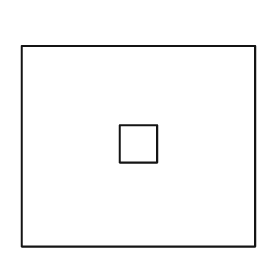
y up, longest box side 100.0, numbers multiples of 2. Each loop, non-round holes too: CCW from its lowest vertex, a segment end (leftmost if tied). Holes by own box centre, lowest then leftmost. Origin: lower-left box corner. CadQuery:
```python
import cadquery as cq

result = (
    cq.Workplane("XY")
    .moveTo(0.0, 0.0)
    .lineTo(100.0, 0.0)
    .lineTo(100.0, 86.0)
    .lineTo(0.0, 86.0)
    .close()
    .moveTo(42.0, 36.0)
    .lineTo(58.0, 36.0)
    .lineTo(58.0, 52.0)
    .lineTo(42.0, 52.0)
    .close()
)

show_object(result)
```